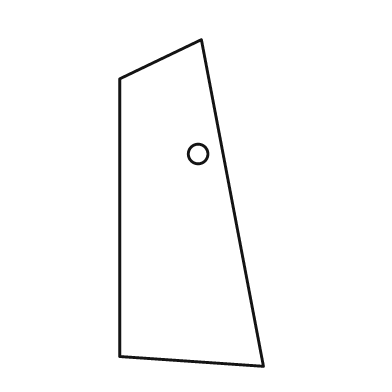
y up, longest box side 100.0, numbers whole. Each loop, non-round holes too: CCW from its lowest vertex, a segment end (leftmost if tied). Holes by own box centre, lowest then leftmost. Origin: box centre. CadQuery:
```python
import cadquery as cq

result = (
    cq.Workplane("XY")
    .moveTo(22.0, -50.0)
    .lineTo(3.0, 50.0)
    .lineTo(-22.0, 38.0)
    .lineTo(-22.0, -47.0)
    .close()
    .moveTo(2.0, 15.0)
    .circle(3.0)
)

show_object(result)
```